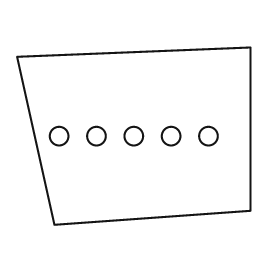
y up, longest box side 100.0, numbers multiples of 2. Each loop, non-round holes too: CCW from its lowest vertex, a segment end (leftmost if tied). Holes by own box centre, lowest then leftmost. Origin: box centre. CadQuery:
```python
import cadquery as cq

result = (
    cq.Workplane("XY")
    .moveTo(-34.0, -38.0)
    .lineTo(50.0, -32.0)
    .lineTo(50.0, 38.0)
    .lineTo(-50.0, 34.0)
    .close()
    .moveTo(-32.0, 0.0)
    .circle(4.0)
    .moveTo(-16.0, 0.0)
    .circle(4.0)
    .moveTo(0.0, 0.0)
    .circle(4.0)
    .moveTo(16.0, 0.0)
    .circle(4.0)
    .moveTo(32.0, 0.0)
    .circle(4.0)
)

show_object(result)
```